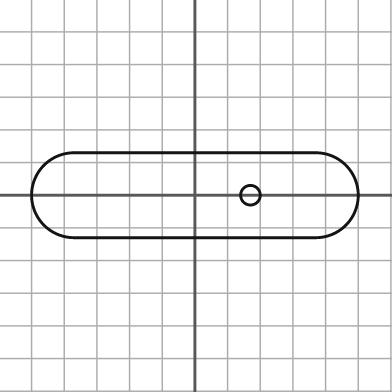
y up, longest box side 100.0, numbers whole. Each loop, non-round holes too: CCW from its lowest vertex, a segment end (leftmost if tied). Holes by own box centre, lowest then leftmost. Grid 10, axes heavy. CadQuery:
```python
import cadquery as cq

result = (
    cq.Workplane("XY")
    .moveTo(-37.0, -13.0)
    .lineTo(37.0, -13.0)
    .threePointArc((50.0, 0.0), (37.0, 13.0))
    .lineTo(-37.0, 13.0)
    .threePointArc((-50.0, 0.0), (-37.0, -13.0))
    .close()
    .moveTo(17.0, 0.0)
    .circle(3.0)
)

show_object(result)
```